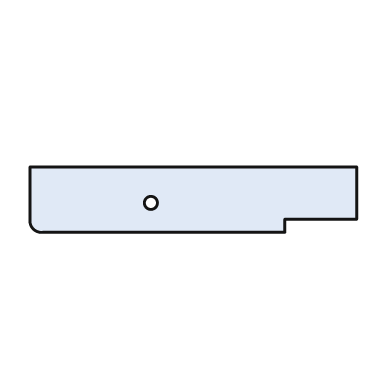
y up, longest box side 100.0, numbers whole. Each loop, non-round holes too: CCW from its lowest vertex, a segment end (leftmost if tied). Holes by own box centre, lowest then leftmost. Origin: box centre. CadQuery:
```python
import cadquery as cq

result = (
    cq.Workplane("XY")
    .moveTo(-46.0, -10.0)
    .lineTo(28.0, -10.0)
    .lineTo(28.0, -6.0)
    .lineTo(50.0, -6.0)
    .lineTo(50.0, 10.0)
    .lineTo(-50.0, 10.0)
    .lineTo(-50.0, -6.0)
    .threePointArc((-49.0, -9.0), (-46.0, -10.0))
    .close()
    .moveTo(-13.0, -1.0)
    .circle(2.0)
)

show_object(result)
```